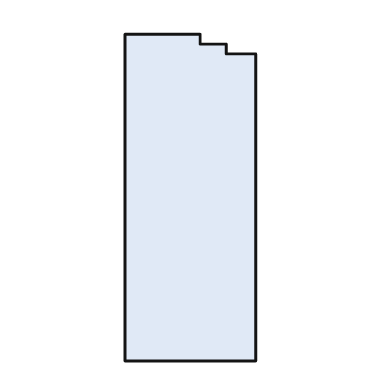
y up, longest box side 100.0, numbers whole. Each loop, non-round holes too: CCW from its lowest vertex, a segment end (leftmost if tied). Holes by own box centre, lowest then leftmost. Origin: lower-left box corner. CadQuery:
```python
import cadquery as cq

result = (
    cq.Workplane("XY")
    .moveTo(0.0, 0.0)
    .lineTo(40.0, 0.0)
    .lineTo(40.0, 94.0)
    .lineTo(31.0, 94.0)
    .lineTo(31.0, 97.0)
    .lineTo(23.0, 97.0)
    .lineTo(23.0, 100.0)
    .lineTo(0.0, 100.0)
    .close()
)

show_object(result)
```